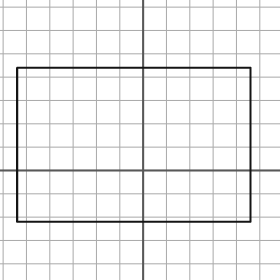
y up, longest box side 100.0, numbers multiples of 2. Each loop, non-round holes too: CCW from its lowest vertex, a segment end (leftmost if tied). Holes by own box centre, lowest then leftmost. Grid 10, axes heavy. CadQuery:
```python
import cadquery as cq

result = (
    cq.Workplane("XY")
    .moveTo(-54.0, -22.0)
    .lineTo(46.0, -22.0)
    .lineTo(46.0, 44.0)
    .lineTo(-54.0, 44.0)
    .close()
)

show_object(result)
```